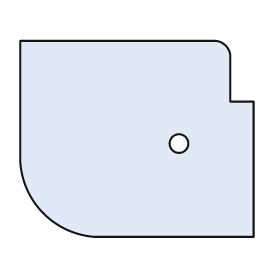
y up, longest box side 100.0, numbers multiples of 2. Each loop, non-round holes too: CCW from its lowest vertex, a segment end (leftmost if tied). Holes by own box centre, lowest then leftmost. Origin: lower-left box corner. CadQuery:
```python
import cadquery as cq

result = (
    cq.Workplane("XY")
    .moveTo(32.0, 0.0)
    .lineTo(100.0, 0.0)
    .lineTo(100.0, 58.0)
    .lineTo(90.0, 58.0)
    .lineTo(90.0, 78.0)
    .threePointArc((88.0, 82.0), (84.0, 84.0))
    .lineTo(0.0, 84.0)
    .lineTo(0.0, 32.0)
    .threePointArc((10.0, 10.0), (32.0, 0.0))
    .close()
    .moveTo(68.0, 40.0)
    .circle(4.0)
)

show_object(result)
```